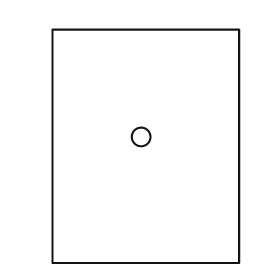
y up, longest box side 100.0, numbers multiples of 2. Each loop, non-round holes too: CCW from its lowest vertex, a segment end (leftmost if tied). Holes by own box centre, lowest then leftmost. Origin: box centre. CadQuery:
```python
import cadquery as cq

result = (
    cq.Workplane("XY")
    .moveTo(-40.0, -50.0)
    .lineTo(40.0, -50.0)
    .lineTo(40.0, 50.0)
    .lineTo(-40.0, 50.0)
    .close()
    .moveTo(-2.0, 4.0)
    .circle(4.0)
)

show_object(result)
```